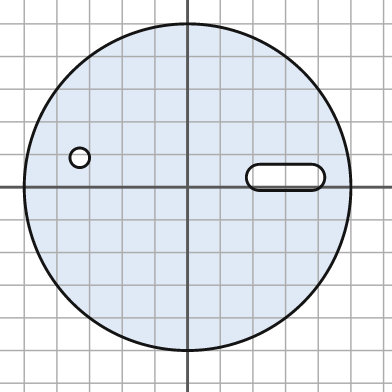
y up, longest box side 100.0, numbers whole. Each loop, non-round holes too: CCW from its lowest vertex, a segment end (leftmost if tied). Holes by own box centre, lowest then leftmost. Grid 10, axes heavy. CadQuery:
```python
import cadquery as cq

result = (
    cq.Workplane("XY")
    .moveTo(0.0, 0.0)
    .circle(50.0)
    .moveTo(22.0, -1.0)
    .lineTo(38.0, -1.0)
    .threePointArc((42.0, 3.0), (38.0, 7.0))
    .lineTo(22.0, 7.0)
    .threePointArc((18.0, 3.0), (22.0, -1.0))
    .close()
    .moveTo(-33.0, 9.0)
    .circle(3.0)
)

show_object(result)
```